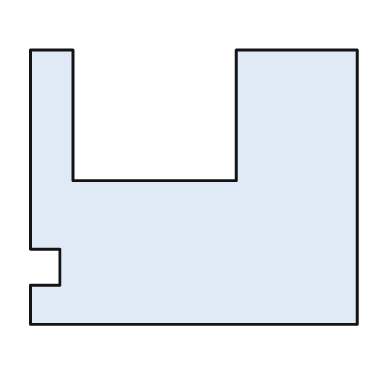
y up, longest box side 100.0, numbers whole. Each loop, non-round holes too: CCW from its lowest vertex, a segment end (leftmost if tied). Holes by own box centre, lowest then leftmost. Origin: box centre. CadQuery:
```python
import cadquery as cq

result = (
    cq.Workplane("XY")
    .moveTo(-50.0, -42.0)
    .lineTo(50.0, -42.0)
    .lineTo(50.0, 42.0)
    .lineTo(13.0, 42.0)
    .lineTo(13.0, 2.0)
    .lineTo(-37.0, 2.0)
    .lineTo(-37.0, 42.0)
    .lineTo(-50.0, 42.0)
    .lineTo(-50.0, -19.0)
    .lineTo(-41.0, -19.0)
    .lineTo(-41.0, -30.0)
    .lineTo(-50.0, -30.0)
    .close()
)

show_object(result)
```